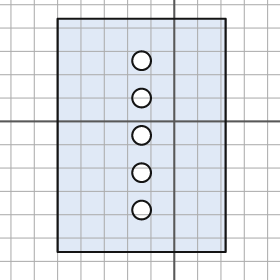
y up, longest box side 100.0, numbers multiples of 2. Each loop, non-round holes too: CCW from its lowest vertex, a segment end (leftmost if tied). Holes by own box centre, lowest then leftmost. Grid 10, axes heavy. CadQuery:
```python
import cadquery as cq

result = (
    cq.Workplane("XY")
    .moveTo(-50.0, -56.0)
    .lineTo(22.0, -56.0)
    .lineTo(22.0, 44.0)
    .lineTo(-50.0, 44.0)
    .close()
    .moveTo(-14.0, -38.0)
    .circle(4.0)
    .moveTo(-14.0, -22.0)
    .circle(4.0)
    .moveTo(-14.0, -6.0)
    .circle(4.0)
    .moveTo(-14.0, 10.0)
    .circle(4.0)
    .moveTo(-14.0, 26.0)
    .circle(4.0)
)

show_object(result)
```